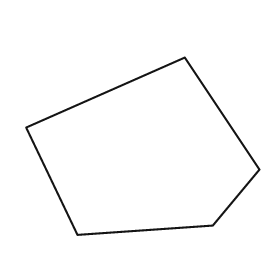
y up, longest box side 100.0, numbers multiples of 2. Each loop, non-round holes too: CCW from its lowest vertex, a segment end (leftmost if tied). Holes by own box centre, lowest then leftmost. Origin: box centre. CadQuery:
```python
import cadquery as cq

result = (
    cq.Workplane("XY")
    .moveTo(-28.0, -38.0)
    .lineTo(30.0, -34.0)
    .lineTo(50.0, -10.0)
    .lineTo(18.0, 38.0)
    .lineTo(-50.0, 8.0)
    .close()
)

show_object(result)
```